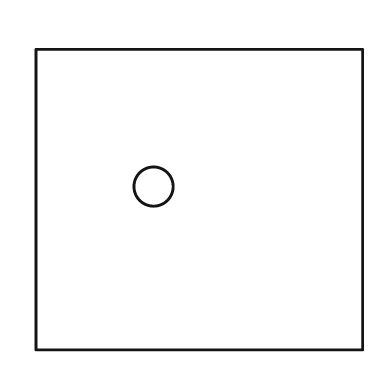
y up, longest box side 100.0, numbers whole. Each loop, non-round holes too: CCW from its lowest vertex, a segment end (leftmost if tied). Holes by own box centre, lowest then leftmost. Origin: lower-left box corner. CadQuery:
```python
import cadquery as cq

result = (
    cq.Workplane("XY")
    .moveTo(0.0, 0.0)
    .lineTo(100.0, 0.0)
    .lineTo(100.0, 92.0)
    .lineTo(0.0, 92.0)
    .close()
    .moveTo(36.0, 50.0)
    .circle(6.0)
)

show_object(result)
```